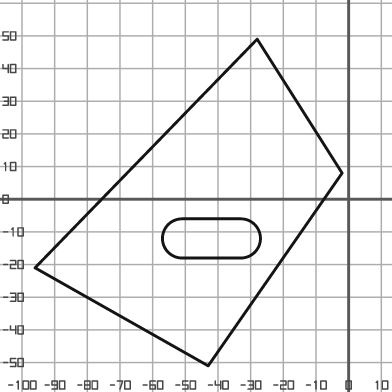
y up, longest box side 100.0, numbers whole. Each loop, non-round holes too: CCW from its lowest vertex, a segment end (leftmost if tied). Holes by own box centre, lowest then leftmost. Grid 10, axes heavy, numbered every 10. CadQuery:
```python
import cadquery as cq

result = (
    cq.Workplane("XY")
    .moveTo(-43.0, -51.0)
    .lineTo(-2.0, 8.0)
    .lineTo(-28.0, 49.0)
    .lineTo(-96.0, -21.0)
    .close()
    .moveTo(-51.0, -18.0)
    .lineTo(-33.0, -18.0)
    .threePointArc((-27.0, -12.0), (-33.0, -6.0))
    .lineTo(-51.0, -6.0)
    .threePointArc((-57.0, -12.0), (-51.0, -18.0))
    .close()
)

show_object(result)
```